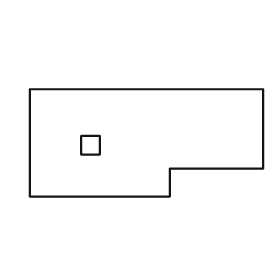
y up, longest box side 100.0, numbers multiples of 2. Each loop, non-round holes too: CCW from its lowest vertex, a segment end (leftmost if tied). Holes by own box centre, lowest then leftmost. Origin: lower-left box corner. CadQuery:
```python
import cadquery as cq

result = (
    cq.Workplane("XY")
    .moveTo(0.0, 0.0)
    .lineTo(60.0, 0.0)
    .lineTo(60.0, 12.0)
    .lineTo(100.0, 12.0)
    .lineTo(100.0, 46.0)
    .lineTo(0.0, 46.0)
    .close()
    .moveTo(22.0, 18.0)
    .lineTo(30.0, 18.0)
    .lineTo(30.0, 26.0)
    .lineTo(22.0, 26.0)
    .close()
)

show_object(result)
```